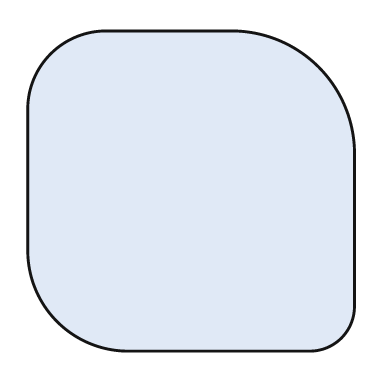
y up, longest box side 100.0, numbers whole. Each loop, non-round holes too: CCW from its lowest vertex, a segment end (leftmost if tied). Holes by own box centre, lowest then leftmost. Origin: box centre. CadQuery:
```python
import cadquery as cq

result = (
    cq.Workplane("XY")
    .moveTo(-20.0, -49.0)
    .lineTo(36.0, -49.0)
    .threePointArc((46.0, -45.0), (50.0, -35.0))
    .lineTo(50.0, 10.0)
    .threePointArc((39.0, 38.0), (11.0, 49.0))
    .lineTo(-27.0, 49.0)
    .threePointArc((-43.0, 42.0), (-50.0, 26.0))
    .lineTo(-50.0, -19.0)
    .threePointArc((-41.0, -40.0), (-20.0, -49.0))
    .close()
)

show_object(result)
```